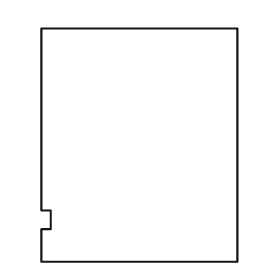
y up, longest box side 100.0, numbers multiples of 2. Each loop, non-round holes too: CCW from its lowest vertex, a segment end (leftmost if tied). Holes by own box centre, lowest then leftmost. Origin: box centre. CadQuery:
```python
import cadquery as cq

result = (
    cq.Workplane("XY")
    .moveTo(-42.0, -50.0)
    .lineTo(42.0, -50.0)
    .lineTo(42.0, 50.0)
    .lineTo(-42.0, 50.0)
    .lineTo(-42.0, -28.0)
    .lineTo(-38.0, -28.0)
    .lineTo(-38.0, -36.0)
    .lineTo(-42.0, -36.0)
    .close()
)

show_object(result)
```